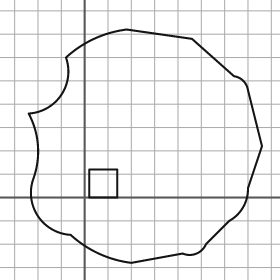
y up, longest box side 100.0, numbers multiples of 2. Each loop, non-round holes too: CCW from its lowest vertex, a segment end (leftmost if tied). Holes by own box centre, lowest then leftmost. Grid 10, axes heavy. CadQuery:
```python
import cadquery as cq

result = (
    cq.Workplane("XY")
    .moveTo(20.0, -28.0)
    .lineTo(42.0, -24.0)
    .threePointArc((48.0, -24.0), (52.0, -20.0))
    .lineTo(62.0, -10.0)
    .threePointArc((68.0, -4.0), (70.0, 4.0))
    .lineTo(76.0, 22.0)
    .lineTo(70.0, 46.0)
    .threePointArc((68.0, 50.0), (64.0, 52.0))
    .lineTo(46.0, 68.0)
    .lineTo(18.0, 72.0)
    .threePointArc((4.0, 68.0), (-8.0, 60.0))
    .threePointArc((-10.0, 44.0), (-24.0, 36.0))
    .threePointArc((-20.0, 22.0), (-22.0, 8.0))
    .threePointArc((-20.0, -8.0), (-6.0, -16.0))
    .threePointArc((6.0, -24.0), (20.0, -28.0))
    .close()
    .moveTo(2.0, 0.0)
    .lineTo(14.0, 0.0)
    .lineTo(14.0, 12.0)
    .lineTo(2.0, 12.0)
    .close()
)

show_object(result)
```